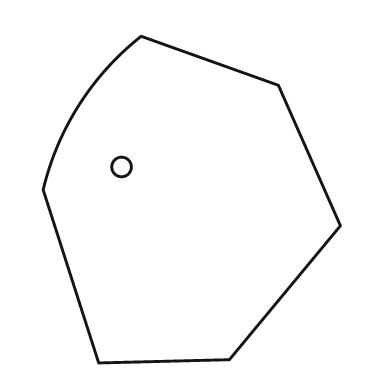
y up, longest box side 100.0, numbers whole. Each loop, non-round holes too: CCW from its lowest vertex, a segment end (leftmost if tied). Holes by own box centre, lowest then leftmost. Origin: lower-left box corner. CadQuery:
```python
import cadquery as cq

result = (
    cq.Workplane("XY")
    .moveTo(17.0, 0.0)
    .lineTo(57.0, 1.0)
    .lineTo(91.0, 42.0)
    .lineTo(72.0, 85.0)
    .lineTo(30.0, 100.0)
    .threePointArc((11.0, 79.0), (0.0, 53.0))
    .close()
    .moveTo(24.0, 60.0)
    .circle(3.0)
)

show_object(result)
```